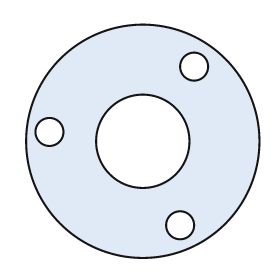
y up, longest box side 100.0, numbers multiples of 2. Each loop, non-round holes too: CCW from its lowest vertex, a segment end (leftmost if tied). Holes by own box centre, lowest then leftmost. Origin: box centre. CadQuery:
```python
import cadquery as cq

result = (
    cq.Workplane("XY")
    .moveTo(0.0, 0.0)
    .circle(50.0)
    .moveTo(16.0, -36.0)
    .circle(6.0)
    .moveTo(0.0, 0.0)
    .circle(20.0)
    .moveTo(-40.0, 4.0)
    .circle(6.0)
    .moveTo(22.0, 32.0)
    .circle(6.0)
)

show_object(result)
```